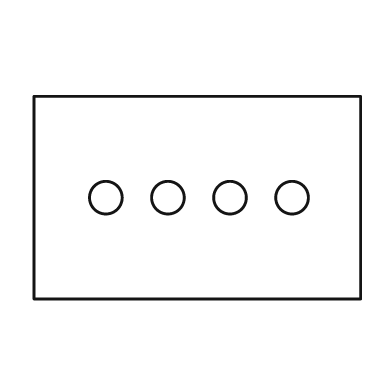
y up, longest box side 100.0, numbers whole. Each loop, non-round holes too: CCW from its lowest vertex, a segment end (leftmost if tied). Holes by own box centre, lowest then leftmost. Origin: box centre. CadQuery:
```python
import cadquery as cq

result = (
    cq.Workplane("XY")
    .moveTo(-50.0, -31.0)
    .lineTo(50.0, -31.0)
    .lineTo(50.0, 31.0)
    .lineTo(-50.0, 31.0)
    .close()
    .moveTo(-28.0, 0.0)
    .circle(5.0)
    .moveTo(-9.0, 0.0)
    .circle(5.0)
    .moveTo(10.0, 0.0)
    .circle(5.0)
    .moveTo(29.0, 0.0)
    .circle(5.0)
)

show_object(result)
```